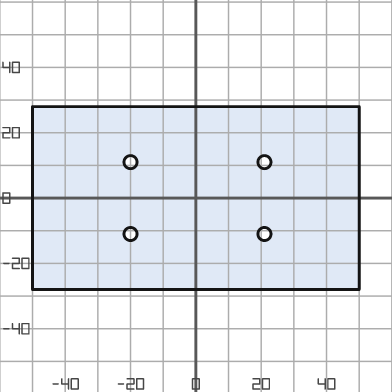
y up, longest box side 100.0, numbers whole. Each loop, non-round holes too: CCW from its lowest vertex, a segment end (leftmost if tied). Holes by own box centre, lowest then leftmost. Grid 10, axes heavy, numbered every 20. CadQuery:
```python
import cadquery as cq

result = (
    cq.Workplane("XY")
    .moveTo(-50.0, -28.0)
    .lineTo(50.0, -28.0)
    .lineTo(50.0, 28.0)
    .lineTo(-50.0, 28.0)
    .close()
    .moveTo(-20.0, -11.0)
    .circle(2.0)
    .moveTo(21.0, -11.0)
    .circle(2.0)
    .moveTo(-20.0, 11.0)
    .circle(2.0)
    .moveTo(21.0, 11.0)
    .circle(2.0)
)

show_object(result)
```